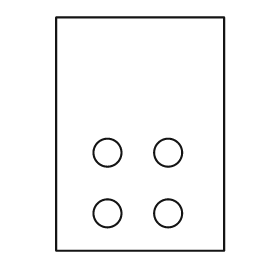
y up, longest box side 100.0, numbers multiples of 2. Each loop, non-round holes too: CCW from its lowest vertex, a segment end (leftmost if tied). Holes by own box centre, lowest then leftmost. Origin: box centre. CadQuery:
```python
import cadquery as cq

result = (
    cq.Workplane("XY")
    .moveTo(-36.0, -50.0)
    .lineTo(36.0, -50.0)
    .lineTo(36.0, 50.0)
    .lineTo(-36.0, 50.0)
    .close()
    .moveTo(-14.0, -34.0)
    .circle(6.0)
    .moveTo(12.0, -34.0)
    .circle(6.0)
    .moveTo(-14.0, -8.0)
    .circle(6.0)
    .moveTo(12.0, -8.0)
    .circle(6.0)
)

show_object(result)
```